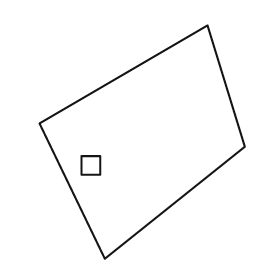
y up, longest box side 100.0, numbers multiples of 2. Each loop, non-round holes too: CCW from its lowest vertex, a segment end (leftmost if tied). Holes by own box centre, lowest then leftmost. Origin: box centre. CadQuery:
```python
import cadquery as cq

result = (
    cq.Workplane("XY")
    .moveTo(-16.0, -50.0)
    .lineTo(44.0, -2.0)
    .lineTo(28.0, 50.0)
    .lineTo(-44.0, 8.0)
    .close()
    .moveTo(-26.0, -14.0)
    .lineTo(-18.0, -14.0)
    .lineTo(-18.0, -6.0)
    .lineTo(-26.0, -6.0)
    .close()
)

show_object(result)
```